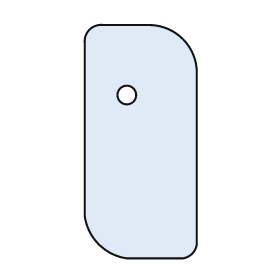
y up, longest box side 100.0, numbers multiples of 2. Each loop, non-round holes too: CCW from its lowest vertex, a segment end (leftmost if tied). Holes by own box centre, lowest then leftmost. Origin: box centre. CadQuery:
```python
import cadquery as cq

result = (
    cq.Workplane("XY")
    .moveTo(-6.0, -50.0)
    .lineTo(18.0, -50.0)
    .threePointArc((22.0, -48.0), (24.0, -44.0))
    .lineTo(24.0, 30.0)
    .threePointArc((18.0, 44.0), (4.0, 50.0))
    .lineTo(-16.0, 50.0)
    .threePointArc((-22.0, 48.0), (-24.0, 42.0))
    .lineTo(-24.0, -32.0)
    .threePointArc((-18.0, -44.0), (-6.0, -50.0))
    .close()
    .moveTo(-6.0, 20.0)
    .circle(4.0)
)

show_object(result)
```